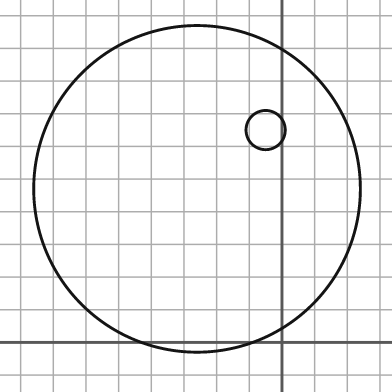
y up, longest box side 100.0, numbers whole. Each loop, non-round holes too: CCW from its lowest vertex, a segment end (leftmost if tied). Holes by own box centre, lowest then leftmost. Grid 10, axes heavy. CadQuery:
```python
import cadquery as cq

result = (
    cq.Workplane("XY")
    .moveTo(-26.0, 47.0)
    .circle(50.0)
    .moveTo(-5.0, 65.0)
    .circle(6.0)
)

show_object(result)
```